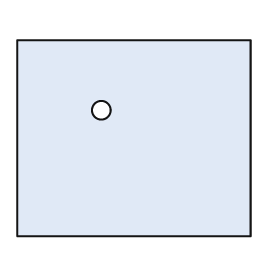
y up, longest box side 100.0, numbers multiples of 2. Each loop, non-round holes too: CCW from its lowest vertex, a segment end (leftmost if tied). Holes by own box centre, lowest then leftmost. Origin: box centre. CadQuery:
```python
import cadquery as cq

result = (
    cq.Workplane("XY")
    .moveTo(-50.0, -42.0)
    .lineTo(50.0, -42.0)
    .lineTo(50.0, 42.0)
    .lineTo(-50.0, 42.0)
    .close()
    .moveTo(-14.0, 12.0)
    .circle(4.0)
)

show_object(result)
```